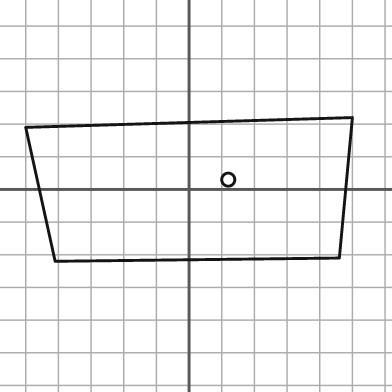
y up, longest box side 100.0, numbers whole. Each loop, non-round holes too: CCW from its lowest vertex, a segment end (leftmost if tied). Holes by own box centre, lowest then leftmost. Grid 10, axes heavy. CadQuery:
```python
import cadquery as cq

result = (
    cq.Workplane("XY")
    .moveTo(-41.0, -22.0)
    .lineTo(46.0, -21.0)
    .lineTo(50.0, 22.0)
    .lineTo(-50.0, 19.0)
    .close()
    .moveTo(12.0, 3.0)
    .circle(2.0)
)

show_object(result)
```